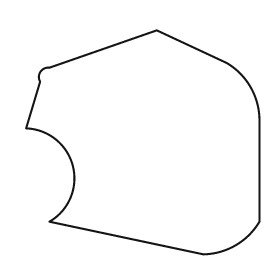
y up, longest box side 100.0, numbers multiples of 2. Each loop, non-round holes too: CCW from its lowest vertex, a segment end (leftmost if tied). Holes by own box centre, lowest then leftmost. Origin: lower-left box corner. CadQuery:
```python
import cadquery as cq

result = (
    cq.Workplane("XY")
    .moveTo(76.0, 0.0)
    .threePointArc((90.0, 4.0), (100.0, 14.0))
    .lineTo(100.0, 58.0)
    .threePointArc((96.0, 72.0), (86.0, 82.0))
    .lineTo(56.0, 96.0)
    .lineTo(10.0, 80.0)
    .threePointArc((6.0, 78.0), (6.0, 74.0))
    .lineTo(0.0, 54.0)
    .threePointArc((20.0, 38.0), (10.0, 14.0))
    .close()
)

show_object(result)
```